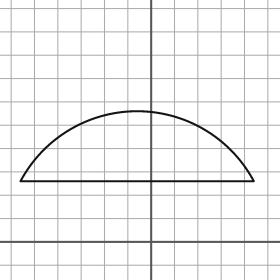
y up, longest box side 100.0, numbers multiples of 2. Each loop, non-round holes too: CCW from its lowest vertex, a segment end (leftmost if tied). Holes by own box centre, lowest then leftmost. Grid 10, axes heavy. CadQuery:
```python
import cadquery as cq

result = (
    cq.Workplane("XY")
    .moveTo(-56.0, 26.0)
    .lineTo(44.0, 26.0)
    .threePointArc((-6.0, 56.0), (-56.0, 26.0))
    .close()
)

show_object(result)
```